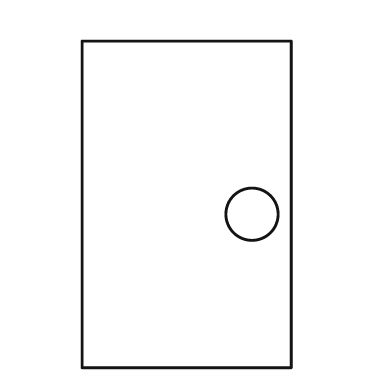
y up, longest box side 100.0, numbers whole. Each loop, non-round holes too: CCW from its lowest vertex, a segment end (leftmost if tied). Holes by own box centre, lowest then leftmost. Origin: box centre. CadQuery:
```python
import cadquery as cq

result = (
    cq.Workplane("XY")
    .moveTo(-32.0, -50.0)
    .lineTo(32.0, -50.0)
    .lineTo(32.0, 50.0)
    .lineTo(-32.0, 50.0)
    .close()
    .moveTo(20.0, -3.0)
    .circle(8.0)
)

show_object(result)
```